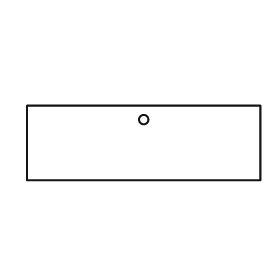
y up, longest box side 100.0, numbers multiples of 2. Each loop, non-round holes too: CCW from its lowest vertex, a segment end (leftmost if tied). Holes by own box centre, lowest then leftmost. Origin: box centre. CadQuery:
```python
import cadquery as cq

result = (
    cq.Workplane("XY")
    .moveTo(-50.0, -16.0)
    .lineTo(50.0, -16.0)
    .lineTo(50.0, 16.0)
    .lineTo(-50.0, 16.0)
    .close()
    .moveTo(0.0, 10.0)
    .circle(2.0)
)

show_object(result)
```